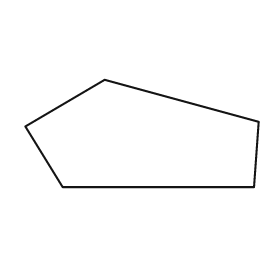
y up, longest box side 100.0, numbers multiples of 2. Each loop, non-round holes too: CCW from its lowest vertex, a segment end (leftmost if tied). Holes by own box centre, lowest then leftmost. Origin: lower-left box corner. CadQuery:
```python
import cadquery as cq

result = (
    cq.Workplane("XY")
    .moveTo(16.0, 0.0)
    .lineTo(98.0, 0.0)
    .lineTo(100.0, 28.0)
    .lineTo(34.0, 46.0)
    .lineTo(0.0, 26.0)
    .close()
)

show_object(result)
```